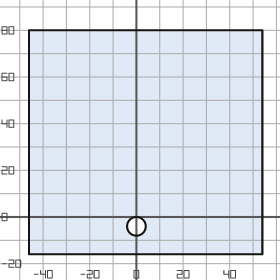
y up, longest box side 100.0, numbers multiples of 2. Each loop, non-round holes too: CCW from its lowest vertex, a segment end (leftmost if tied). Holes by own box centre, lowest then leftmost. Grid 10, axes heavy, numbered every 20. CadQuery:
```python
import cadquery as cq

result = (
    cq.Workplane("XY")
    .moveTo(-46.0, -16.0)
    .lineTo(54.0, -16.0)
    .lineTo(54.0, 80.0)
    .lineTo(-46.0, 80.0)
    .close()
    .moveTo(0.0, -4.0)
    .circle(4.0)
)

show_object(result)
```